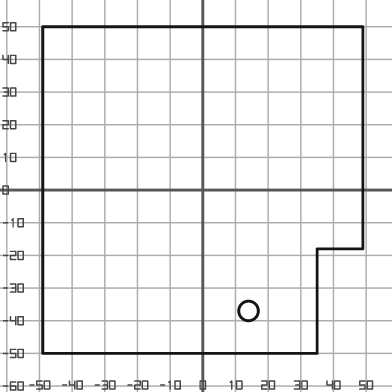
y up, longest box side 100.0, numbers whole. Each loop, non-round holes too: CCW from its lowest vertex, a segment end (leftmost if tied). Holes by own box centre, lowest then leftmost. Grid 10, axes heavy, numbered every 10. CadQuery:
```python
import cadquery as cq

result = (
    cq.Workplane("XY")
    .moveTo(-49.0, -50.0)
    .lineTo(35.0, -50.0)
    .lineTo(35.0, -18.0)
    .lineTo(49.0, -18.0)
    .lineTo(49.0, 50.0)
    .lineTo(-49.0, 50.0)
    .close()
    .moveTo(14.0, -37.0)
    .circle(3.0)
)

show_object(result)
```